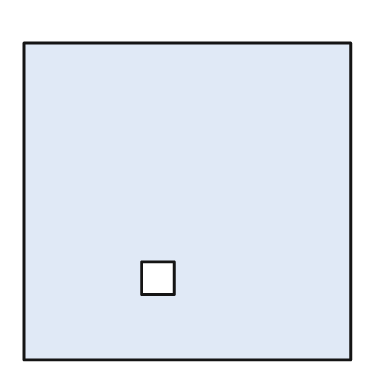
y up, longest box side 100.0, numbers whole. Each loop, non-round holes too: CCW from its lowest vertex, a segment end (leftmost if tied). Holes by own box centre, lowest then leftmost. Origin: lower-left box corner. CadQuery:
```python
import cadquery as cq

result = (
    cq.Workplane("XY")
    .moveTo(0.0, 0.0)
    .lineTo(100.0, 0.0)
    .lineTo(100.0, 97.0)
    .lineTo(0.0, 97.0)
    .close()
    .moveTo(36.0, 20.0)
    .lineTo(46.0, 20.0)
    .lineTo(46.0, 30.0)
    .lineTo(36.0, 30.0)
    .close()
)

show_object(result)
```